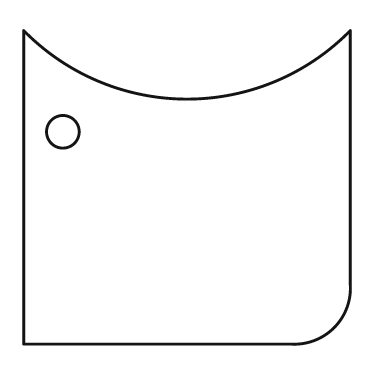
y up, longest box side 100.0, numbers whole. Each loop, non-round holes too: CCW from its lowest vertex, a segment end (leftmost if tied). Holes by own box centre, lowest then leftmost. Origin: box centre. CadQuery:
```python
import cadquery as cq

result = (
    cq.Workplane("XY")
    .moveTo(-50.0, -48.0)
    .lineTo(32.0, -48.0)
    .threePointArc((45.0, -43.0), (50.0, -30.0))
    .lineTo(50.0, 48.0)
    .threePointArc((0.0, 27.0), (-50.0, 48.0))
    .close()
    .moveTo(-38.0, 17.0)
    .circle(5.0)
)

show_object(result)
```